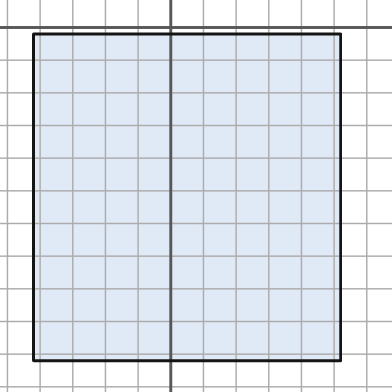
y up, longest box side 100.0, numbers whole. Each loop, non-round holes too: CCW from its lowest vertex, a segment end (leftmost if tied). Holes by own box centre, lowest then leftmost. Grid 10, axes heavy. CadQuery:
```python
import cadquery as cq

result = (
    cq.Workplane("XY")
    .moveTo(-42.0, -102.0)
    .lineTo(52.0, -102.0)
    .lineTo(52.0, -2.0)
    .lineTo(-42.0, -2.0)
    .close()
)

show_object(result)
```